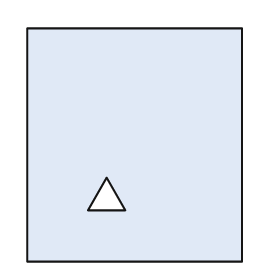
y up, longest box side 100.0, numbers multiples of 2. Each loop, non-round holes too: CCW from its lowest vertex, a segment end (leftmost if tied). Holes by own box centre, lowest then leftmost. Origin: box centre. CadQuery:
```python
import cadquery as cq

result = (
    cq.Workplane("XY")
    .moveTo(-46.0, -50.0)
    .lineTo(46.0, -50.0)
    .lineTo(46.0, 50.0)
    .lineTo(-46.0, 50.0)
    .close()
    .moveTo(-20.0, -28.0)
    .lineTo(-4.0, -28.0)
    .lineTo(-12.0, -14.0)
    .close()
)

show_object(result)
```